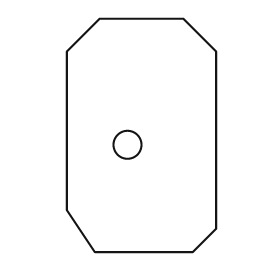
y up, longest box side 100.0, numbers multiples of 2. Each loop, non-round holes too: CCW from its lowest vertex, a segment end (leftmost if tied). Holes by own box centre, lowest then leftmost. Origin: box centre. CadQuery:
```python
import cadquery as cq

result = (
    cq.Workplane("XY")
    .moveTo(-20.0, -50.0)
    .lineTo(22.0, -50.0)
    .lineTo(32.0, -40.0)
    .lineTo(32.0, 36.0)
    .lineTo(18.0, 50.0)
    .lineTo(-18.0, 50.0)
    .lineTo(-32.0, 36.0)
    .lineTo(-32.0, -32.0)
    .close()
    .moveTo(-6.0, -4.0)
    .circle(6.0)
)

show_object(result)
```